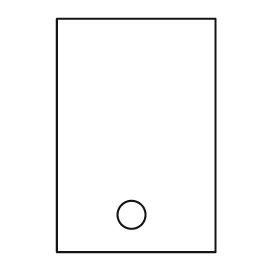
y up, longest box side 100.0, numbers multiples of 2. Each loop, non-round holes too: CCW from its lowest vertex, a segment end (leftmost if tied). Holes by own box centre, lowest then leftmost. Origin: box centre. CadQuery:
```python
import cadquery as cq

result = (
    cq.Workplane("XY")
    .moveTo(-34.0, -50.0)
    .lineTo(34.0, -50.0)
    .lineTo(34.0, 50.0)
    .lineTo(-34.0, 50.0)
    .close()
    .moveTo(-2.0, -34.0)
    .circle(6.0)
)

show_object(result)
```